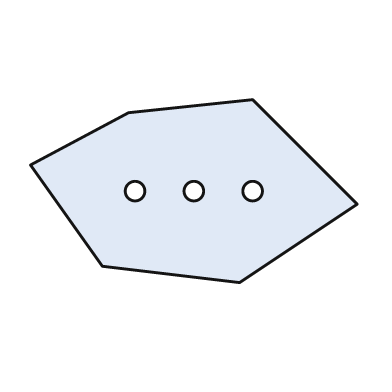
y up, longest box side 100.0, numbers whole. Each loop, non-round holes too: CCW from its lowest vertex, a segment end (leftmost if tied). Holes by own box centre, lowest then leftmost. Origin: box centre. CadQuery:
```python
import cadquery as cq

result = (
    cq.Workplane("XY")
    .moveTo(14.0, -28.0)
    .lineTo(50.0, -4.0)
    .lineTo(18.0, 28.0)
    .lineTo(-20.0, 24.0)
    .lineTo(-50.0, 8.0)
    .lineTo(-28.0, -23.0)
    .close()
    .moveTo(-18.0, 0.0)
    .circle(3.0)
    .moveTo(0.0, 0.0)
    .circle(3.0)
    .moveTo(18.0, 0.0)
    .circle(3.0)
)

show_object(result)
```